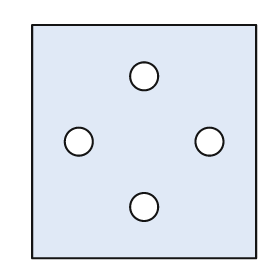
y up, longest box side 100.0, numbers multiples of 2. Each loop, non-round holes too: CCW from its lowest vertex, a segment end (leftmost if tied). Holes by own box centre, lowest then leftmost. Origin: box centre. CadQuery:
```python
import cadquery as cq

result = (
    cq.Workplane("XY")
    .moveTo(-48.0, -50.0)
    .lineTo(48.0, -50.0)
    .lineTo(48.0, 50.0)
    .lineTo(-48.0, 50.0)
    .close()
    .moveTo(0.0, -28.0)
    .circle(6.0)
    .moveTo(-28.0, 0.0)
    .circle(6.0)
    .moveTo(28.0, 0.0)
    .circle(6.0)
    .moveTo(0.0, 28.0)
    .circle(6.0)
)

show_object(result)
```